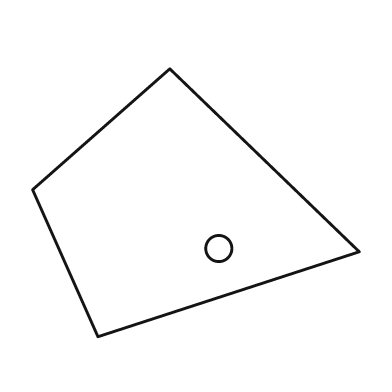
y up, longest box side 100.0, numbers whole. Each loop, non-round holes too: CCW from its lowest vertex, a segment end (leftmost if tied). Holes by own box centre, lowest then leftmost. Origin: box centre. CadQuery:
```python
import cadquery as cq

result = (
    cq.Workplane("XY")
    .moveTo(-30.0, -41.0)
    .lineTo(50.0, -15.0)
    .lineTo(-8.0, 41.0)
    .lineTo(-50.0, 4.0)
    .close()
    .moveTo(7.0, -14.0)
    .circle(4.0)
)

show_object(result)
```